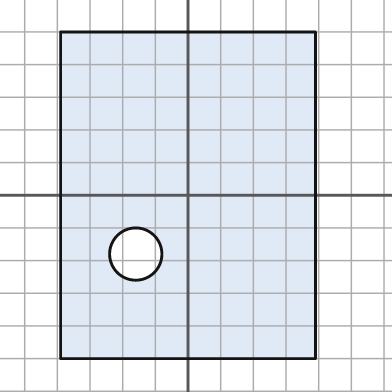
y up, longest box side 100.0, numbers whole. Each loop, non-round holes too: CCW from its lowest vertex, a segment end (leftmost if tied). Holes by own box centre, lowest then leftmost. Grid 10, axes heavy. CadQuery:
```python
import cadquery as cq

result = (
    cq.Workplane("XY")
    .moveTo(-39.0, -50.0)
    .lineTo(39.0, -50.0)
    .lineTo(39.0, 50.0)
    .lineTo(-39.0, 50.0)
    .close()
    .moveTo(-16.0, -18.0)
    .circle(8.0)
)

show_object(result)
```